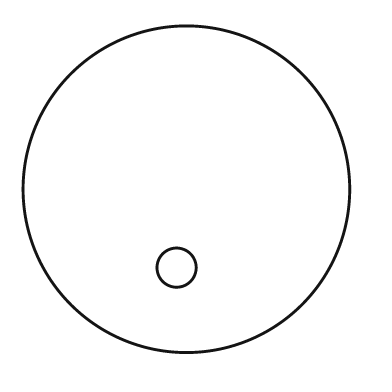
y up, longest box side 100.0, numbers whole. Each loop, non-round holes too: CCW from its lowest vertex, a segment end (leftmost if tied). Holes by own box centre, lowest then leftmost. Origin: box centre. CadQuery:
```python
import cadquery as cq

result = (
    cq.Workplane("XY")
    .moveTo(0.0, 0.0)
    .circle(50.0)
    .moveTo(-3.0, -24.0)
    .circle(6.0)
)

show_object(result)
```